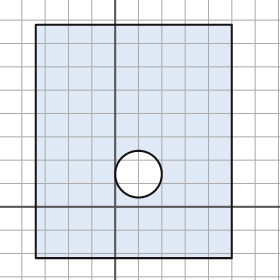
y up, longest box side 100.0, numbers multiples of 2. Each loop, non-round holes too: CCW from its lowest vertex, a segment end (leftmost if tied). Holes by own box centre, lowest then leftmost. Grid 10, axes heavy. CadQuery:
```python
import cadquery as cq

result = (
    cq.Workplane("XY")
    .moveTo(-34.0, -22.0)
    .lineTo(50.0, -22.0)
    .lineTo(50.0, 78.0)
    .lineTo(-34.0, 78.0)
    .close()
    .moveTo(10.0, 14.0)
    .circle(10.0)
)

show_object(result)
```